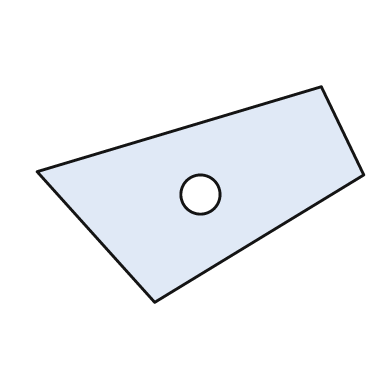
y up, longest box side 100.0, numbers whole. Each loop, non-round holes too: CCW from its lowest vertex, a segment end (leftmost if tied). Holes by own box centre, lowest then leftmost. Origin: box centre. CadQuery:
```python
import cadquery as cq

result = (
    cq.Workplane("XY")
    .moveTo(-14.0, -33.0)
    .lineTo(50.0, 6.0)
    .lineTo(37.0, 33.0)
    .lineTo(-50.0, 7.0)
    .close()
    .moveTo(0.0, 0.0)
    .circle(6.0)
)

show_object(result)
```